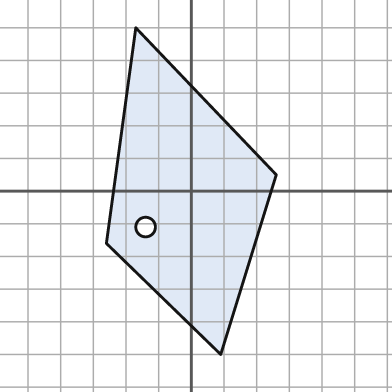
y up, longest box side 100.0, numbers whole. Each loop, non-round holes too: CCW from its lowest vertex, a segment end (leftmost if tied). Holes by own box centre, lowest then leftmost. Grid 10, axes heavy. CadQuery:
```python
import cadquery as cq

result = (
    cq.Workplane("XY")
    .moveTo(9.0, -50.0)
    .lineTo(26.0, 5.0)
    .lineTo(-17.0, 50.0)
    .lineTo(-26.0, -16.0)
    .close()
    .moveTo(-14.0, -11.0)
    .circle(3.0)
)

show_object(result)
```